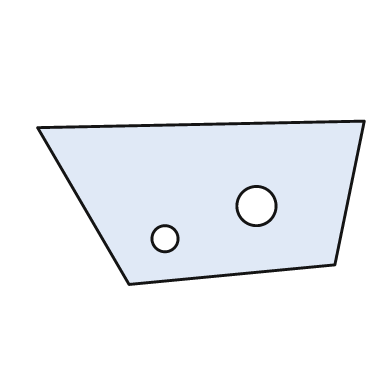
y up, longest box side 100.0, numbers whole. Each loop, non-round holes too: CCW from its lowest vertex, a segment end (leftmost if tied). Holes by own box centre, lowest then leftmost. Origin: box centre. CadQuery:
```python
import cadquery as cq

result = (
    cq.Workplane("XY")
    .moveTo(-22.0, -25.0)
    .lineTo(41.0, -19.0)
    .lineTo(50.0, 25.0)
    .lineTo(-50.0, 23.0)
    .close()
    .moveTo(-11.0, -11.0)
    .circle(4.0)
    .moveTo(17.0, -1.0)
    .circle(6.0)
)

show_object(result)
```